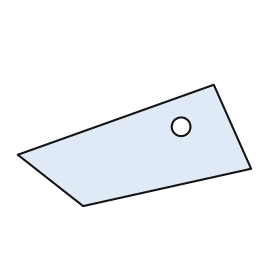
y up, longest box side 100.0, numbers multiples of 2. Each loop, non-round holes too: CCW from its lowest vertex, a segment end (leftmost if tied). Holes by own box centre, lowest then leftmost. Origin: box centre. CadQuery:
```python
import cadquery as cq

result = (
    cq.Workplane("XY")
    .moveTo(-22.0, -26.0)
    .lineTo(50.0, -10.0)
    .lineTo(34.0, 26.0)
    .lineTo(-50.0, -4.0)
    .close()
    .moveTo(20.0, 8.0)
    .circle(4.0)
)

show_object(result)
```